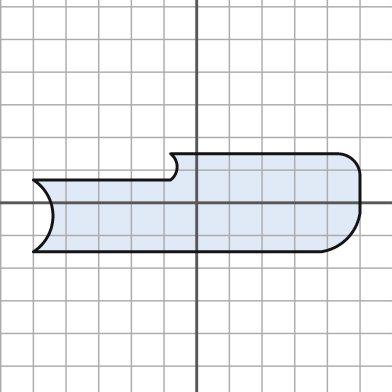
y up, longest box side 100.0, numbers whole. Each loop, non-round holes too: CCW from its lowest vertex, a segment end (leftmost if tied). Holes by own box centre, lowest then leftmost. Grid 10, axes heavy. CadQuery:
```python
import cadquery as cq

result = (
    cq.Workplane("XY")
    .moveTo(-50.0, -15.0)
    .lineTo(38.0, -15.0)
    .threePointArc((46.0, -11.0), (50.0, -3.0))
    .lineTo(50.0, 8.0)
    .threePointArc((48.0, 13.0), (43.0, 15.0))
    .lineTo(-8.0, 15.0)
    .threePointArc((-6.0, 11.0), (-8.0, 7.0))
    .lineTo(-50.0, 7.0)
    .threePointArc((-44.0, -4.0), (-50.0, -15.0))
    .close()
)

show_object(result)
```